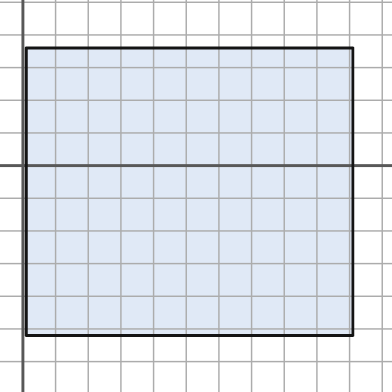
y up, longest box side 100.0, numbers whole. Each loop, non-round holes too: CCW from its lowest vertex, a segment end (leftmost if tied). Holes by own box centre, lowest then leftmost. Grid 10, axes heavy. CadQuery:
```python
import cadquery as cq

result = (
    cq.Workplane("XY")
    .moveTo(1.0, -52.0)
    .lineTo(101.0, -52.0)
    .lineTo(101.0, 36.0)
    .lineTo(1.0, 36.0)
    .close()
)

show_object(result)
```